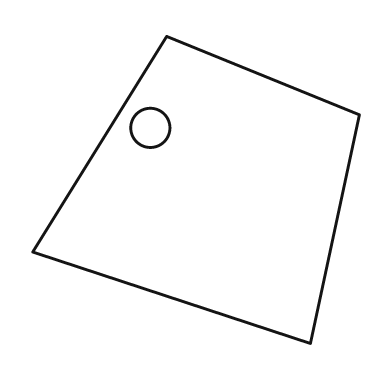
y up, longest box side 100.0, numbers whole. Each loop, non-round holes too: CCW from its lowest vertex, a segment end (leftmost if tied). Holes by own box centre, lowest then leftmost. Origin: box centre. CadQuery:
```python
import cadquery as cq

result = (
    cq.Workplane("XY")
    .moveTo(35.0, -47.0)
    .lineTo(50.0, 23.0)
    .lineTo(-9.0, 47.0)
    .lineTo(-50.0, -19.0)
    .close()
    .moveTo(-14.0, 19.0)
    .circle(6.0)
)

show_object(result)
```